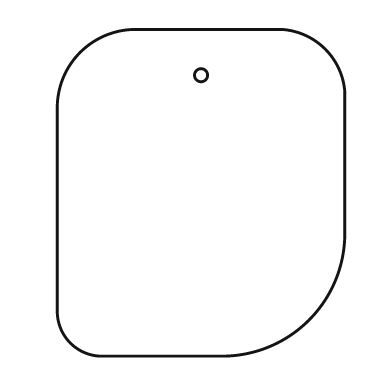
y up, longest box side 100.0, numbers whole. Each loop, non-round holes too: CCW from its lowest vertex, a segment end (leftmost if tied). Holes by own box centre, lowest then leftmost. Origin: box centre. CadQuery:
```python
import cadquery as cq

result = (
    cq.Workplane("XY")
    .moveTo(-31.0, -50.0)
    .lineTo(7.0, -50.0)
    .threePointArc((33.0, -39.0), (44.0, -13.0))
    .lineTo(44.0, 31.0)
    .threePointArc((38.0, 44.0), (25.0, 50.0))
    .lineTo(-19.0, 50.0)
    .threePointArc((-37.0, 43.0), (-44.0, 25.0))
    .lineTo(-44.0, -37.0)
    .threePointArc((-40.0, -46.0), (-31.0, -50.0))
    .close()
    .moveTo(0.0, 36.0)
    .circle(2.0)
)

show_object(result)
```